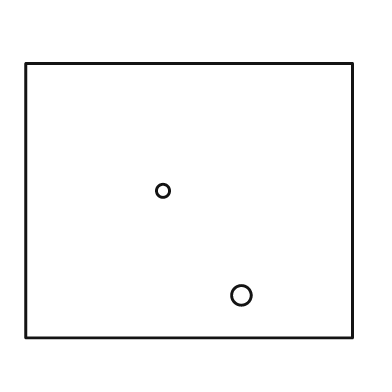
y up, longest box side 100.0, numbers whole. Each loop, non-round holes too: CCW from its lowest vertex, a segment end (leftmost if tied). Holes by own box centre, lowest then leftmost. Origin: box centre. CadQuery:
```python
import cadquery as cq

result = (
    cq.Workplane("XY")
    .moveTo(-50.0, -42.0)
    .lineTo(50.0, -42.0)
    .lineTo(50.0, 42.0)
    .lineTo(-50.0, 42.0)
    .close()
    .moveTo(16.0, -29.0)
    .circle(3.0)
    .moveTo(-8.0, 3.0)
    .circle(2.0)
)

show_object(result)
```